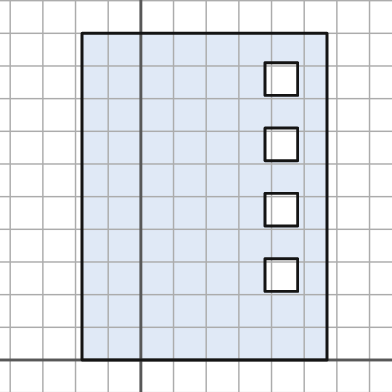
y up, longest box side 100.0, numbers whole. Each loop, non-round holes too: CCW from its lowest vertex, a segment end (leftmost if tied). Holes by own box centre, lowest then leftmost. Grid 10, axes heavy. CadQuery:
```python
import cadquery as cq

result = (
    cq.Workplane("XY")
    .moveTo(-18.0, 0.0)
    .lineTo(57.0, 0.0)
    .lineTo(57.0, 100.0)
    .lineTo(-18.0, 100.0)
    .close()
    .moveTo(38.0, 21.0)
    .lineTo(48.0, 21.0)
    .lineTo(48.0, 31.0)
    .lineTo(38.0, 31.0)
    .close()
    .moveTo(38.0, 41.0)
    .lineTo(48.0, 41.0)
    .lineTo(48.0, 51.0)
    .lineTo(38.0, 51.0)
    .close()
    .moveTo(38.0, 61.0)
    .lineTo(48.0, 61.0)
    .lineTo(48.0, 71.0)
    .lineTo(38.0, 71.0)
    .close()
    .moveTo(38.0, 81.0)
    .lineTo(48.0, 81.0)
    .lineTo(48.0, 91.0)
    .lineTo(38.0, 91.0)
    .close()
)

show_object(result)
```